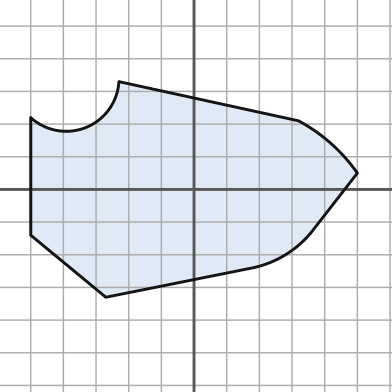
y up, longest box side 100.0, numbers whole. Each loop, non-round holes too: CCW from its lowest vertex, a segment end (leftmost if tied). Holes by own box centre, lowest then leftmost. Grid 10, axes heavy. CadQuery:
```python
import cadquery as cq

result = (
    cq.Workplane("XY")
    .moveTo(-27.0, -33.0)
    .lineTo(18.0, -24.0)
    .threePointArc((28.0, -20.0), (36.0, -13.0))
    .lineTo(50.0, 5.0)
    .threePointArc((42.0, 14.0), (32.0, 21.0))
    .lineTo(-23.0, 33.0)
    .threePointArc((-33.0, 19.0), (-50.0, 22.0))
    .lineTo(-50.0, -14.0)
    .close()
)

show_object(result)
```